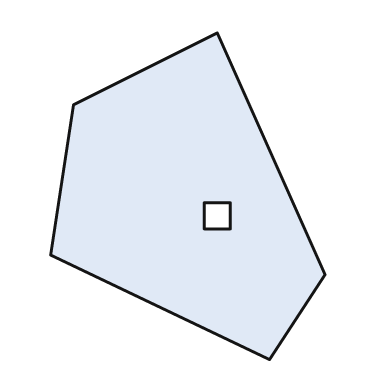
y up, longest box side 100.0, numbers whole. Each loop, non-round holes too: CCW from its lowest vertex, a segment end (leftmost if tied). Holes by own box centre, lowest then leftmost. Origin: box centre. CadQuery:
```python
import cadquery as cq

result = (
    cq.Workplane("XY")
    .moveTo(25.0, -50.0)
    .lineTo(42.0, -24.0)
    .lineTo(9.0, 50.0)
    .lineTo(-35.0, 28.0)
    .lineTo(-42.0, -18.0)
    .close()
    .moveTo(5.0, -10.0)
    .lineTo(13.0, -10.0)
    .lineTo(13.0, -2.0)
    .lineTo(5.0, -2.0)
    .close()
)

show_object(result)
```